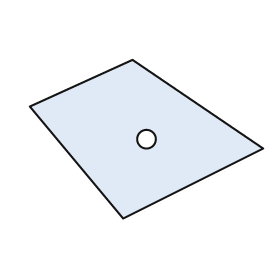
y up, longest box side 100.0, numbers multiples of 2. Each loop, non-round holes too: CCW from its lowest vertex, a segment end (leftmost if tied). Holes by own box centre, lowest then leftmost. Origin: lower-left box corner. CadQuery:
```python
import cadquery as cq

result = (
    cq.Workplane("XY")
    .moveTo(40.0, 0.0)
    .lineTo(100.0, 30.0)
    .lineTo(44.0, 68.0)
    .lineTo(0.0, 48.0)
    .close()
    .moveTo(50.0, 34.0)
    .circle(4.0)
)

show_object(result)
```